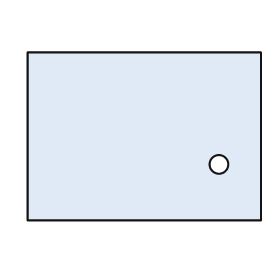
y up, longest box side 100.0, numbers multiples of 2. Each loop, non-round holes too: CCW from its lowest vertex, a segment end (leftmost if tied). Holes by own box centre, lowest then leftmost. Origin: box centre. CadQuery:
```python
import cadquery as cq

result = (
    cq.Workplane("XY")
    .moveTo(-50.0, -36.0)
    .lineTo(50.0, -36.0)
    .lineTo(50.0, 36.0)
    .lineTo(-50.0, 36.0)
    .close()
    .moveTo(32.0, -12.0)
    .circle(4.0)
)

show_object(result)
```